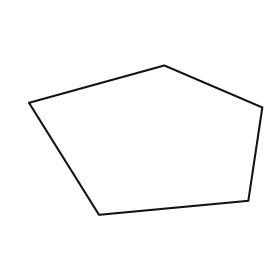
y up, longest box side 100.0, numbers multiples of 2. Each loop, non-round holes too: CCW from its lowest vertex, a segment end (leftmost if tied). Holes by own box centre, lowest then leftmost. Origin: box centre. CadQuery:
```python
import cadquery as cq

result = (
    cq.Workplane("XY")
    .moveTo(-20.0, -32.0)
    .lineTo(44.0, -26.0)
    .lineTo(50.0, 14.0)
    .lineTo(8.0, 32.0)
    .lineTo(-50.0, 16.0)
    .close()
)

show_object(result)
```